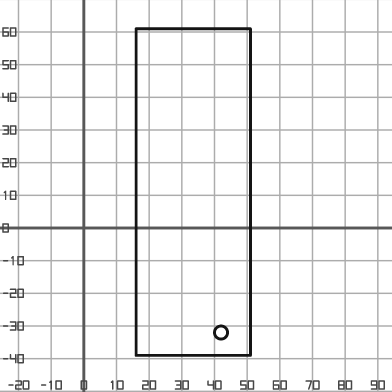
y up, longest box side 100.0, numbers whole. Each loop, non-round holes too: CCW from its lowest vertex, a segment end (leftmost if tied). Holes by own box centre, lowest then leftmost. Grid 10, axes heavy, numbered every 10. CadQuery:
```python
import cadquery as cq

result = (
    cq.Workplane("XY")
    .moveTo(16.0, -39.0)
    .lineTo(51.0, -39.0)
    .lineTo(51.0, 61.0)
    .lineTo(16.0, 61.0)
    .close()
    .moveTo(42.0, -32.0)
    .circle(2.0)
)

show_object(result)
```